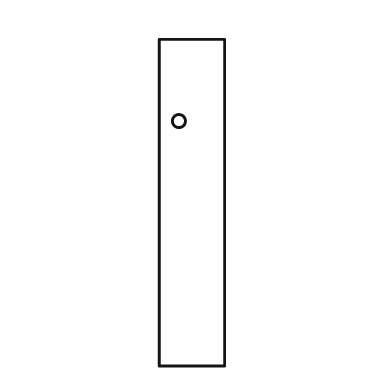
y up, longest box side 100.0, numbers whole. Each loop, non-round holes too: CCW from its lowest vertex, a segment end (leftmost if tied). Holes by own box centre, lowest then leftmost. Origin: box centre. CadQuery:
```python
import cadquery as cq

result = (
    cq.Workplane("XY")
    .moveTo(-10.0, -50.0)
    .lineTo(10.0, -50.0)
    .lineTo(10.0, 50.0)
    .lineTo(-10.0, 50.0)
    .close()
    .moveTo(-4.0, 25.0)
    .circle(2.0)
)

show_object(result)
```